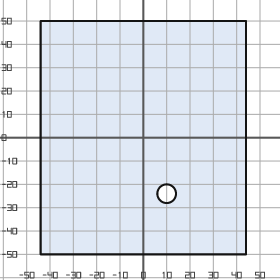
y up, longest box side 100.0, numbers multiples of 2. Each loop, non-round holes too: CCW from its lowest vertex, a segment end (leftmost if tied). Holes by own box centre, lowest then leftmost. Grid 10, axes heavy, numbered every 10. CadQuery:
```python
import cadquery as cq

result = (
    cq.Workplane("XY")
    .moveTo(-44.0, -50.0)
    .lineTo(44.0, -50.0)
    .lineTo(44.0, 50.0)
    .lineTo(-44.0, 50.0)
    .close()
    .moveTo(10.0, -24.0)
    .circle(4.0)
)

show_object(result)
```